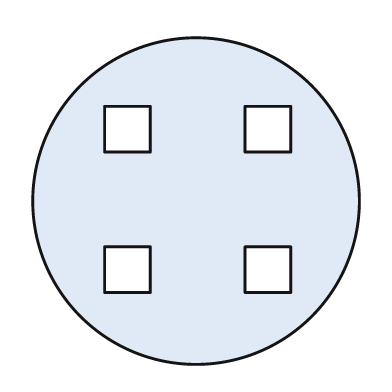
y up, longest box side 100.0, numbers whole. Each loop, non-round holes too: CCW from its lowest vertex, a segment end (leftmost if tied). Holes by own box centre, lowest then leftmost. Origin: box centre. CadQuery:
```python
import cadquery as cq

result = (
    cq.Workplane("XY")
    .moveTo(0.0, 0.0)
    .circle(50.0)
    .moveTo(-28.0, -28.0)
    .lineTo(-14.0, -28.0)
    .lineTo(-14.0, -14.0)
    .lineTo(-28.0, -14.0)
    .close()
    .moveTo(15.0, -28.0)
    .lineTo(29.0, -28.0)
    .lineTo(29.0, -14.0)
    .lineTo(15.0, -14.0)
    .close()
    .moveTo(-28.0, 15.0)
    .lineTo(-14.0, 15.0)
    .lineTo(-14.0, 29.0)
    .lineTo(-28.0, 29.0)
    .close()
    .moveTo(15.0, 15.0)
    .lineTo(29.0, 15.0)
    .lineTo(29.0, 29.0)
    .lineTo(15.0, 29.0)
    .close()
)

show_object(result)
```